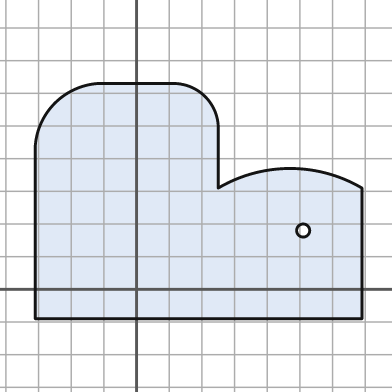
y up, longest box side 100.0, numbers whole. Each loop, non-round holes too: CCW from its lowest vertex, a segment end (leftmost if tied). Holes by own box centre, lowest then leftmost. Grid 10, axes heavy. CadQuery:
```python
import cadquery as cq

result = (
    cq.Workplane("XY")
    .moveTo(-31.0, -9.0)
    .lineTo(69.0, -9.0)
    .lineTo(69.0, 31.0)
    .threePointArc((47.0, 37.0), (25.0, 31.0))
    .lineTo(25.0, 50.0)
    .threePointArc((21.0, 59.0), (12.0, 63.0))
    .lineTo(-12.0, 63.0)
    .threePointArc((-25.0, 57.0), (-31.0, 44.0))
    .close()
    .moveTo(51.0, 18.0)
    .circle(2.0)
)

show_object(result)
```